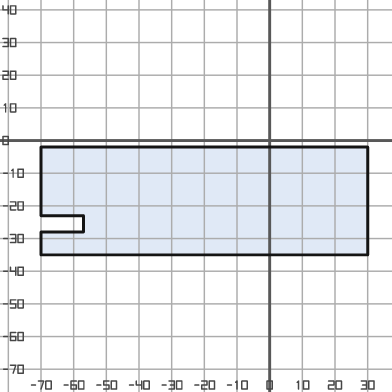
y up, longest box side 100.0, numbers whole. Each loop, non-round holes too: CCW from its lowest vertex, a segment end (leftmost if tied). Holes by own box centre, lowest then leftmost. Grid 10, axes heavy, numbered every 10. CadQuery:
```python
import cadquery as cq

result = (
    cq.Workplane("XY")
    .moveTo(-70.0, -35.0)
    .lineTo(30.0, -35.0)
    .lineTo(30.0, -2.0)
    .lineTo(-70.0, -2.0)
    .lineTo(-70.0, -23.0)
    .lineTo(-57.0, -23.0)
    .lineTo(-57.0, -28.0)
    .lineTo(-70.0, -28.0)
    .close()
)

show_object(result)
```